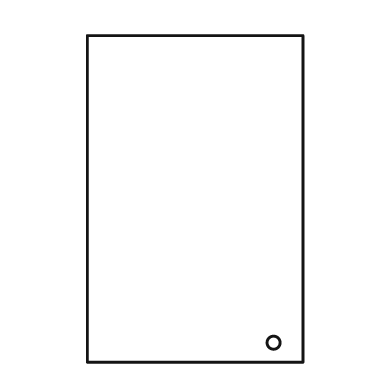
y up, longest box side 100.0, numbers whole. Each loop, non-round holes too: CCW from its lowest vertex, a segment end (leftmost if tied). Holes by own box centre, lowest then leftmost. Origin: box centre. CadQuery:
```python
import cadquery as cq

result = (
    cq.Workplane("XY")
    .moveTo(-33.0, -50.0)
    .lineTo(33.0, -50.0)
    .lineTo(33.0, 50.0)
    .lineTo(-33.0, 50.0)
    .close()
    .moveTo(24.0, -44.0)
    .circle(2.0)
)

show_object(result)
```